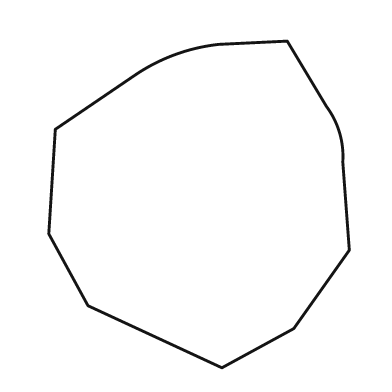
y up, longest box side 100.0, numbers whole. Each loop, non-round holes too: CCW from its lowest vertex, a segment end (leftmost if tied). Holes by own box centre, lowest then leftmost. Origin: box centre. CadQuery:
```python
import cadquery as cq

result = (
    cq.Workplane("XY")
    .moveTo(7.0, -50.0)
    .lineTo(29.0, -38.0)
    .lineTo(46.0, -14.0)
    .lineTo(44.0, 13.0)
    .threePointArc((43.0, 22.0), (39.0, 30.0))
    .lineTo(27.0, 50.0)
    .lineTo(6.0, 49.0)
    .threePointArc((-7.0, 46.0), (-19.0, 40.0))
    .lineTo(-44.0, 23.0)
    .lineTo(-46.0, -9.0)
    .lineTo(-34.0, -31.0)
    .close()
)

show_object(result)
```